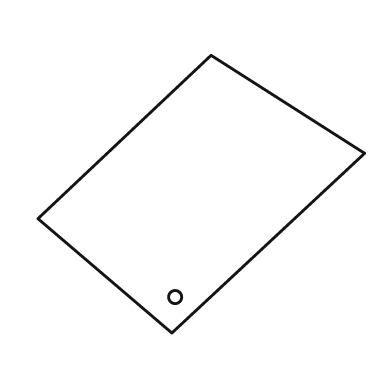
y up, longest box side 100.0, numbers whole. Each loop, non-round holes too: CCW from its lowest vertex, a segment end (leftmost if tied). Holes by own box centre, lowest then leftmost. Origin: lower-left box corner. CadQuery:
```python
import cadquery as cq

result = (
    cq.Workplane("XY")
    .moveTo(41.0, 0.0)
    .lineTo(100.0, 55.0)
    .lineTo(53.0, 85.0)
    .lineTo(0.0, 35.0)
    .close()
    .moveTo(42.0, 11.0)
    .circle(2.0)
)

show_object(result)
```